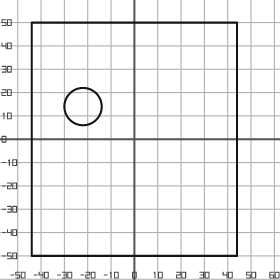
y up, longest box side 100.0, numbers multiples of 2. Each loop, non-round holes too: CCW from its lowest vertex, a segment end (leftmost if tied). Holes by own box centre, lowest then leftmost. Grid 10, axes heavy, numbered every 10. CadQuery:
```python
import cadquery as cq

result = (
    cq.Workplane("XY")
    .moveTo(-44.0, -50.0)
    .lineTo(44.0, -50.0)
    .lineTo(44.0, 50.0)
    .lineTo(-44.0, 50.0)
    .close()
    .moveTo(-22.0, 14.0)
    .circle(8.0)
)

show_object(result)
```